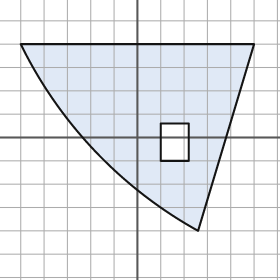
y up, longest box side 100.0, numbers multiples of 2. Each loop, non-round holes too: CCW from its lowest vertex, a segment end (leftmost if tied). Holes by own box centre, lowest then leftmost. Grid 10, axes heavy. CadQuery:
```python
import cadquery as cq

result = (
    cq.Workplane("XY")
    .moveTo(26.0, -40.0)
    .lineTo(50.0, 40.0)
    .lineTo(-50.0, 40.0)
    .threePointArc((-18.0, -6.0), (26.0, -40.0))
    .close()
    .moveTo(10.0, -10.0)
    .lineTo(22.0, -10.0)
    .lineTo(22.0, 6.0)
    .lineTo(10.0, 6.0)
    .close()
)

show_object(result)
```